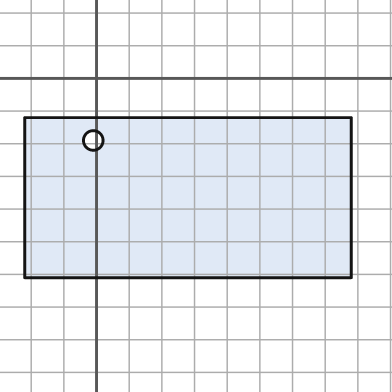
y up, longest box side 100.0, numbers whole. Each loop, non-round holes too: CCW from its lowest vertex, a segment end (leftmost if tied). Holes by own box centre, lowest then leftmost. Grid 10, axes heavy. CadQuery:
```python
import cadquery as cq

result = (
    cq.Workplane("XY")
    .moveTo(-22.0, -61.0)
    .lineTo(78.0, -61.0)
    .lineTo(78.0, -12.0)
    .lineTo(-22.0, -12.0)
    .close()
    .moveTo(-1.0, -19.0)
    .circle(3.0)
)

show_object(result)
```